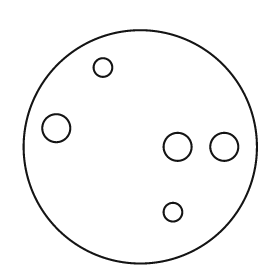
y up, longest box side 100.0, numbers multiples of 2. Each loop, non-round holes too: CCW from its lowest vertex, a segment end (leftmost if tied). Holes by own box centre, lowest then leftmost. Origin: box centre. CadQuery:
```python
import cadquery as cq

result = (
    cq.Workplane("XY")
    .moveTo(0.0, 0.0)
    .circle(50.0)
    .moveTo(14.0, -28.0)
    .circle(4.0)
    .moveTo(16.0, 0.0)
    .circle(6.0)
    .moveTo(36.0, 0.0)
    .circle(6.0)
    .moveTo(-36.0, 8.0)
    .circle(6.0)
    .moveTo(-16.0, 34.0)
    .circle(4.0)
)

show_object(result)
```